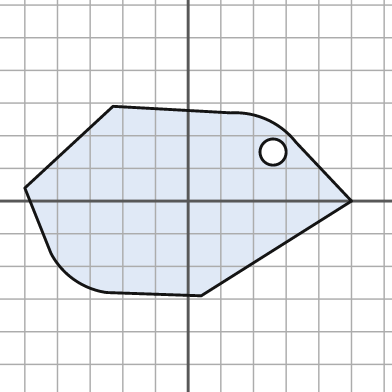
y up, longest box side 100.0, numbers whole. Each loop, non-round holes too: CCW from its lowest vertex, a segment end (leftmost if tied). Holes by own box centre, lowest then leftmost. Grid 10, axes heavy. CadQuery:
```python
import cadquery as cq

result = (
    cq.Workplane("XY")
    .moveTo(4.0, -29.0)
    .lineTo(50.0, 0.0)
    .lineTo(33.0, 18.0)
    .threePointArc((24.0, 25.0), (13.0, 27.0))
    .lineTo(-23.0, 29.0)
    .lineTo(-50.0, 4.0)
    .lineTo(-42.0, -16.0)
    .threePointArc((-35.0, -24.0), (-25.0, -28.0))
    .close()
    .moveTo(26.0, 15.0)
    .circle(4.0)
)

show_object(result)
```